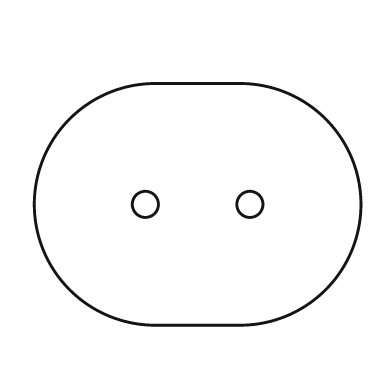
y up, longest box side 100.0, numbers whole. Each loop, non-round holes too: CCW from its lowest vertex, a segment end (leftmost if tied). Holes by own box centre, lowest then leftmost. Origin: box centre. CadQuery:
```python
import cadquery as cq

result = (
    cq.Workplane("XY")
    .moveTo(-13.0, -37.0)
    .lineTo(13.0, -37.0)
    .threePointArc((50.0, 0.0), (13.0, 37.0))
    .lineTo(-13.0, 37.0)
    .threePointArc((-50.0, 0.0), (-13.0, -37.0))
    .close()
    .moveTo(-16.0, 0.0)
    .circle(4.0)
    .moveTo(16.0, 0.0)
    .circle(4.0)
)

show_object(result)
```